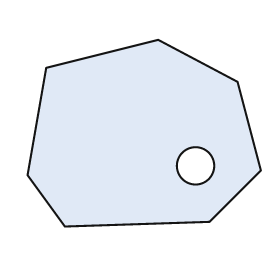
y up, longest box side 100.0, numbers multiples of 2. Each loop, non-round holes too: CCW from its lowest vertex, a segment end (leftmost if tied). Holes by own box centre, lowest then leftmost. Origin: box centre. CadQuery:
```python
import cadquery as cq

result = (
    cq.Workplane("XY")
    .moveTo(-34.0, -40.0)
    .lineTo(28.0, -38.0)
    .lineTo(50.0, -16.0)
    .lineTo(40.0, 22.0)
    .lineTo(6.0, 40.0)
    .lineTo(-42.0, 28.0)
    .lineTo(-50.0, -18.0)
    .close()
    .moveTo(22.0, -14.0)
    .circle(8.0)
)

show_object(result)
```